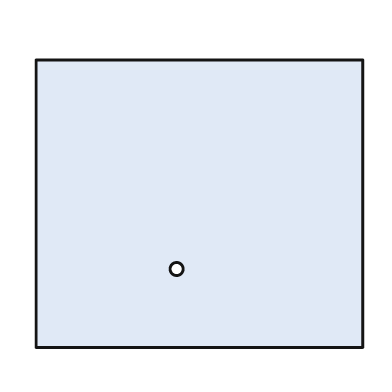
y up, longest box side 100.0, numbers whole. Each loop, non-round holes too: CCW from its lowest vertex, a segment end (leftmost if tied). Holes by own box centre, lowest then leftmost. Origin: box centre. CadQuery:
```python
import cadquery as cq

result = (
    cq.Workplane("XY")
    .moveTo(-50.0, -44.0)
    .lineTo(50.0, -44.0)
    .lineTo(50.0, 44.0)
    .lineTo(-50.0, 44.0)
    .close()
    .moveTo(-7.0, -20.0)
    .circle(2.0)
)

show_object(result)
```